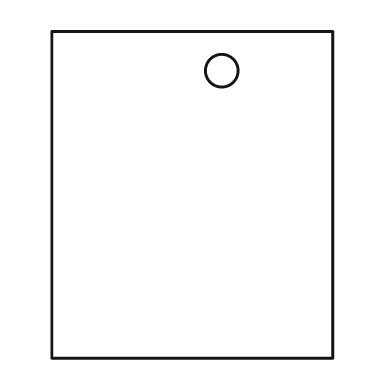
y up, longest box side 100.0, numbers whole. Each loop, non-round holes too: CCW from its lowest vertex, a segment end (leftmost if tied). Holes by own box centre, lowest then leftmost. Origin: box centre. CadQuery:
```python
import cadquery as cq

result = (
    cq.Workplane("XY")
    .moveTo(-43.0, -50.0)
    .lineTo(43.0, -50.0)
    .lineTo(43.0, 50.0)
    .lineTo(-43.0, 50.0)
    .close()
    .moveTo(9.0, 38.0)
    .circle(5.0)
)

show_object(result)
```